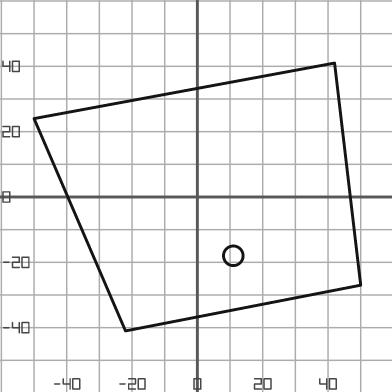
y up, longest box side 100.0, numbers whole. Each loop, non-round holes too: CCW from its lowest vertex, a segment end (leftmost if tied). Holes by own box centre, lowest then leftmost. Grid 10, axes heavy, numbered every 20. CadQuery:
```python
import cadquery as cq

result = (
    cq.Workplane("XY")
    .moveTo(-22.0, -41.0)
    .lineTo(50.0, -27.0)
    .lineTo(42.0, 41.0)
    .lineTo(-50.0, 24.0)
    .close()
    .moveTo(11.0, -18.0)
    .circle(3.0)
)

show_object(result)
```